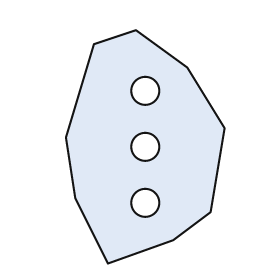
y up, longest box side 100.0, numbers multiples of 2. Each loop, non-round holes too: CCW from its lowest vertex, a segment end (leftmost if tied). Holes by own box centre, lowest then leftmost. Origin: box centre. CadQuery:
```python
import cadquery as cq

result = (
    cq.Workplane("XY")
    .moveTo(-16.0, -50.0)
    .lineTo(12.0, -40.0)
    .lineTo(28.0, -28.0)
    .lineTo(34.0, 8.0)
    .lineTo(18.0, 34.0)
    .lineTo(-4.0, 50.0)
    .lineTo(-22.0, 44.0)
    .lineTo(-34.0, 4.0)
    .lineTo(-30.0, -22.0)
    .close()
    .moveTo(0.0, -24.0)
    .circle(6.0)
    .moveTo(0.0, 0.0)
    .circle(6.0)
    .moveTo(0.0, 24.0)
    .circle(6.0)
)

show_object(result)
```